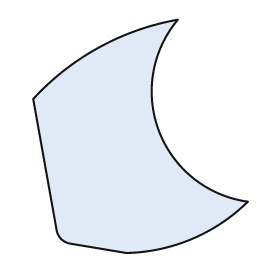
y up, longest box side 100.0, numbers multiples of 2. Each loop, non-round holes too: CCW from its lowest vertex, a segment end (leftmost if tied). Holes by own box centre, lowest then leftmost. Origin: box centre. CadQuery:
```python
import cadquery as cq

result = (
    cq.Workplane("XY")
    .moveTo(-6.0, -50.0)
    .threePointArc((22.0, -44.0), (46.0, -28.0))
    .threePointArc((8.0, 2.0), (16.0, 50.0))
    .threePointArc((-18.0, 38.0), (-46.0, 16.0))
    .lineTo(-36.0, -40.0)
    .threePointArc((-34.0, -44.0), (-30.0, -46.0))
    .close()
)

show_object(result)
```